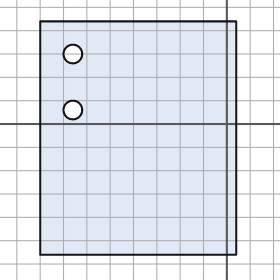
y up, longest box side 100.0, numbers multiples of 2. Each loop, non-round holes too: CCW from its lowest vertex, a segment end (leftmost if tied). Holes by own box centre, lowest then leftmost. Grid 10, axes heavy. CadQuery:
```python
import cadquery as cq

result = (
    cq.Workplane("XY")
    .moveTo(-80.0, -56.0)
    .lineTo(4.0, -56.0)
    .lineTo(4.0, 44.0)
    .lineTo(-80.0, 44.0)
    .close()
    .moveTo(-66.0, 6.0)
    .circle(4.0)
    .moveTo(-66.0, 30.0)
    .circle(4.0)
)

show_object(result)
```